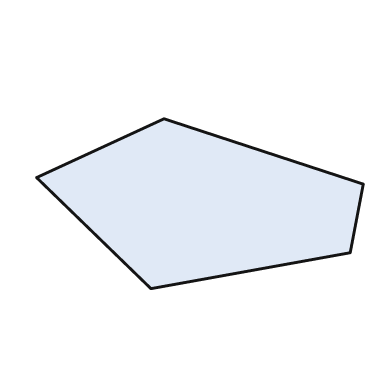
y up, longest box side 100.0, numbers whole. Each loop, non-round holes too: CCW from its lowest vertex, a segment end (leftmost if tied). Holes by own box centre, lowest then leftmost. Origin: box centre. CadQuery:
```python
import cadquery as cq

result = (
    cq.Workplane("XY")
    .moveTo(-15.0, -26.0)
    .lineTo(46.0, -15.0)
    .lineTo(50.0, 6.0)
    .lineTo(-11.0, 26.0)
    .lineTo(-50.0, 8.0)
    .close()
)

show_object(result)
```